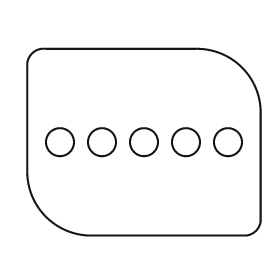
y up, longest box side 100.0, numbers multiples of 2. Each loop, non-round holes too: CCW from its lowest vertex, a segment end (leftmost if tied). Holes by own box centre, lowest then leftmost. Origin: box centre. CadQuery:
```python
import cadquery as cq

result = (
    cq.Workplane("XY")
    .moveTo(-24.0, -40.0)
    .lineTo(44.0, -40.0)
    .threePointArc((48.0, -38.0), (50.0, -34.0))
    .lineTo(50.0, 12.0)
    .threePointArc((42.0, 32.0), (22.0, 40.0))
    .lineTo(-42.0, 40.0)
    .threePointArc((-48.0, 38.0), (-50.0, 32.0))
    .lineTo(-50.0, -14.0)
    .threePointArc((-42.0, -32.0), (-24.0, -40.0))
    .close()
    .moveTo(-36.0, 0.0)
    .circle(6.0)
    .moveTo(-18.0, 0.0)
    .circle(6.0)
    .moveTo(0.0, 0.0)
    .circle(6.0)
    .moveTo(18.0, 0.0)
    .circle(6.0)
    .moveTo(36.0, 0.0)
    .circle(6.0)
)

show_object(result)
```